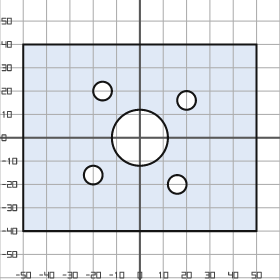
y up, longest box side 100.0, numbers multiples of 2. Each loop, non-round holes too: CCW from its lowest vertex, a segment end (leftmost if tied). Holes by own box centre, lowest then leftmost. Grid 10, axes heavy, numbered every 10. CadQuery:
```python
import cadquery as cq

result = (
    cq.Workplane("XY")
    .moveTo(-50.0, -40.0)
    .lineTo(50.0, -40.0)
    .lineTo(50.0, 40.0)
    .lineTo(-50.0, 40.0)
    .close()
    .moveTo(16.0, -20.0)
    .circle(4.0)
    .moveTo(-20.0, -16.0)
    .circle(4.0)
    .moveTo(0.0, 0.0)
    .circle(12.0)
    .moveTo(20.0, 16.0)
    .circle(4.0)
    .moveTo(-16.0, 20.0)
    .circle(4.0)
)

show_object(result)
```